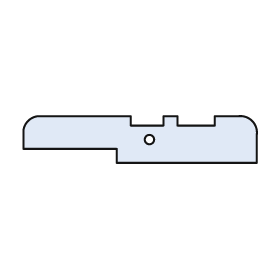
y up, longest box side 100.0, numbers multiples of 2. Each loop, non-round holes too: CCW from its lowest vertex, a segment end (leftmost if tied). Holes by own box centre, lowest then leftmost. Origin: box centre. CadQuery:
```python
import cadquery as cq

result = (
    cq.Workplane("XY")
    .moveTo(-10.0, -10.0)
    .lineTo(50.0, -10.0)
    .lineTo(50.0, 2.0)
    .threePointArc((48.0, 8.0), (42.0, 10.0))
    .lineTo(32.0, 10.0)
    .lineTo(32.0, 6.0)
    .lineTo(16.0, 6.0)
    .lineTo(16.0, 10.0)
    .lineTo(10.0, 10.0)
    .lineTo(10.0, 6.0)
    .lineTo(-4.0, 6.0)
    .lineTo(-4.0, 10.0)
    .lineTo(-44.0, 10.0)
    .threePointArc((-48.0, 8.0), (-50.0, 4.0))
    .lineTo(-50.0, -4.0)
    .lineTo(-10.0, -4.0)
    .close()
    .moveTo(4.0, 0.0)
    .circle(2.0)
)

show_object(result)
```